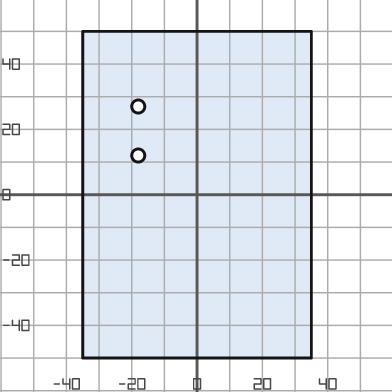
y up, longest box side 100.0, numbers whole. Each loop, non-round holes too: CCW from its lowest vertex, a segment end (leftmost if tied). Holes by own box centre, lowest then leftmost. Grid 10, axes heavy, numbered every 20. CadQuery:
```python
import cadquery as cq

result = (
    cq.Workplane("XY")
    .moveTo(-35.0, -50.0)
    .lineTo(35.0, -50.0)
    .lineTo(35.0, 50.0)
    .lineTo(-35.0, 50.0)
    .close()
    .moveTo(-18.0, 12.0)
    .circle(2.0)
    .moveTo(-18.0, 27.0)
    .circle(2.0)
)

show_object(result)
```